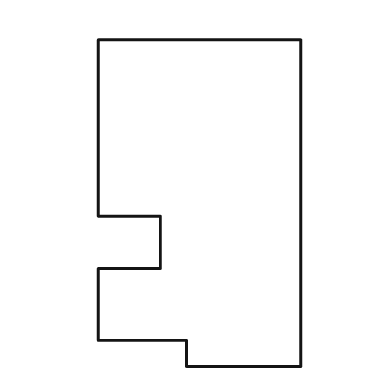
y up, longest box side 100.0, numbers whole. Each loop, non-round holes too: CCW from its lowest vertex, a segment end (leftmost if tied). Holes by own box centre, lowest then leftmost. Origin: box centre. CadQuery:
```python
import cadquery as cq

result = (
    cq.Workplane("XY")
    .moveTo(-4.0, -50.0)
    .lineTo(31.0, -50.0)
    .lineTo(31.0, 50.0)
    .lineTo(-31.0, 50.0)
    .lineTo(-31.0, -4.0)
    .lineTo(-12.0, -4.0)
    .lineTo(-12.0, -20.0)
    .lineTo(-31.0, -20.0)
    .lineTo(-31.0, -42.0)
    .lineTo(-4.0, -42.0)
    .close()
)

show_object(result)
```